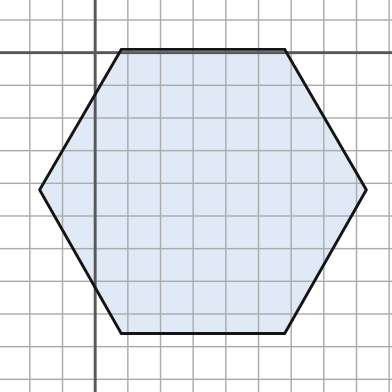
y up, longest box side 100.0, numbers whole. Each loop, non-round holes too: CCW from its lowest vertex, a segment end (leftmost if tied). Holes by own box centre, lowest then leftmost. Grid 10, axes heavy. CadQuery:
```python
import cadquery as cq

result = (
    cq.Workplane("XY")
    .moveTo(8.0, -86.0)
    .lineTo(58.0, -86.0)
    .lineTo(83.0, -42.0)
    .lineTo(58.0, 1.0)
    .lineTo(8.0, 1.0)
    .lineTo(-17.0, -42.0)
    .close()
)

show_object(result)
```